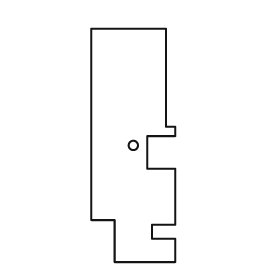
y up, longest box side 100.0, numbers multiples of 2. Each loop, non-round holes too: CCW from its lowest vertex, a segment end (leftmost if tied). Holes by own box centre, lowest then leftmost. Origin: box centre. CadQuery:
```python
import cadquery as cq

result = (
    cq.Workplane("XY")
    .moveTo(-8.0, -50.0)
    .lineTo(18.0, -50.0)
    .lineTo(18.0, -40.0)
    .lineTo(8.0, -40.0)
    .lineTo(8.0, -34.0)
    .lineTo(18.0, -34.0)
    .lineTo(18.0, -10.0)
    .lineTo(6.0, -10.0)
    .lineTo(6.0, 4.0)
    .lineTo(18.0, 4.0)
    .lineTo(18.0, 8.0)
    .lineTo(14.0, 8.0)
    .lineTo(14.0, 50.0)
    .lineTo(-18.0, 50.0)
    .lineTo(-18.0, -32.0)
    .lineTo(-8.0, -32.0)
    .close()
    .moveTo(0.0, 0.0)
    .circle(2.0)
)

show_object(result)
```